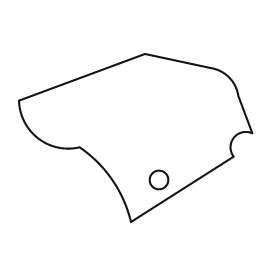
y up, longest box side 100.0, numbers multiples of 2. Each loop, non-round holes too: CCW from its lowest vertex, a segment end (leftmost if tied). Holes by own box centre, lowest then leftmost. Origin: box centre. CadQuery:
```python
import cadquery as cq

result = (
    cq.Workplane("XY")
    .moveTo(-2.0, -36.0)
    .lineTo(42.0, -8.0)
    .threePointArc((42.0, 0.0), (50.0, 2.0))
    .lineTo(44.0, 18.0)
    .threePointArc((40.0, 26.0), (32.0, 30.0))
    .lineTo(4.0, 36.0)
    .lineTo(-50.0, 16.0)
    .threePointArc((-42.0, 0.0), (-24.0, -4.0))
    .threePointArc((-10.0, -18.0), (-2.0, -36.0))
    .close()
    .moveTo(10.0, -18.0)
    .circle(4.0)
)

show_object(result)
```